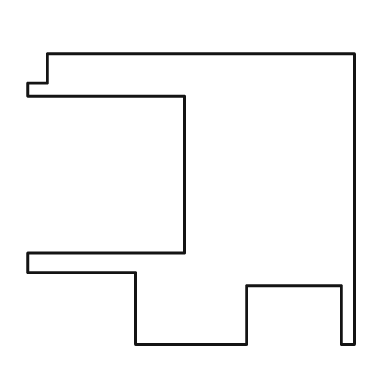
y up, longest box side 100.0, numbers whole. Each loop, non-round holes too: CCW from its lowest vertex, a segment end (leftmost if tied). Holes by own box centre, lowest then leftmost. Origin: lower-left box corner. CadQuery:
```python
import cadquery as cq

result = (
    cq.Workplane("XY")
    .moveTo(33.0, 0.0)
    .lineTo(67.0, 0.0)
    .lineTo(67.0, 18.0)
    .lineTo(96.0, 18.0)
    .lineTo(96.0, 0.0)
    .lineTo(100.0, 0.0)
    .lineTo(100.0, 89.0)
    .lineTo(6.0, 89.0)
    .lineTo(6.0, 80.0)
    .lineTo(0.0, 80.0)
    .lineTo(0.0, 76.0)
    .lineTo(48.0, 76.0)
    .lineTo(48.0, 28.0)
    .lineTo(0.0, 28.0)
    .lineTo(0.0, 22.0)
    .lineTo(33.0, 22.0)
    .close()
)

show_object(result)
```